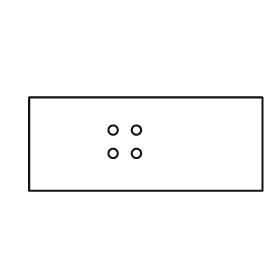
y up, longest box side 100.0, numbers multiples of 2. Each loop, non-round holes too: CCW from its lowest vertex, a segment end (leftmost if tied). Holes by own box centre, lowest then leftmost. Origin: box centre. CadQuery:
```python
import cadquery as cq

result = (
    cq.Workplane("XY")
    .moveTo(-50.0, -20.0)
    .lineTo(50.0, -20.0)
    .lineTo(50.0, 20.0)
    .lineTo(-50.0, 20.0)
    .close()
    .moveTo(-14.0, -4.0)
    .circle(2.0)
    .moveTo(-4.0, -4.0)
    .circle(2.0)
    .moveTo(-14.0, 6.0)
    .circle(2.0)
    .moveTo(-4.0, 6.0)
    .circle(2.0)
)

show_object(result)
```